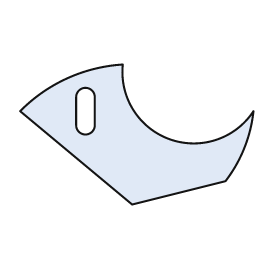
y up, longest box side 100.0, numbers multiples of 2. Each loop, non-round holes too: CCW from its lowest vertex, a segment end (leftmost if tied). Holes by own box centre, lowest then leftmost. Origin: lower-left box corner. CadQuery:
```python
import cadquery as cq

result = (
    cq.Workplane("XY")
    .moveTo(48.0, 0.0)
    .lineTo(88.0, 10.0)
    .threePointArc((96.0, 24.0), (100.0, 40.0))
    .threePointArc((64.0, 28.0), (44.0, 60.0))
    .threePointArc((20.0, 54.0), (0.0, 40.0))
    .close()
    .moveTo(24.0, 34.0)
    .threePointArc((28.0, 30.0), (32.0, 34.0))
    .lineTo(32.0, 46.0)
    .threePointArc((28.0, 50.0), (24.0, 46.0))
    .close()
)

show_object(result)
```